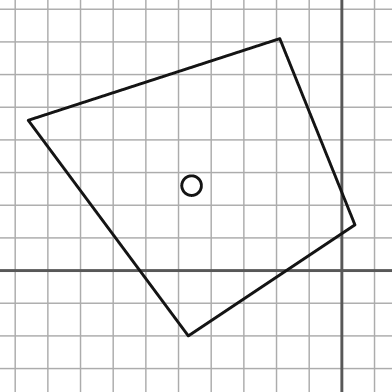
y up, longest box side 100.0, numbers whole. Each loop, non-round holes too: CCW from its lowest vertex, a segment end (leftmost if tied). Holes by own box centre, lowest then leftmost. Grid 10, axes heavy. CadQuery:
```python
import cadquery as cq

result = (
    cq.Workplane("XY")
    .moveTo(-47.0, -20.0)
    .lineTo(4.0, 14.0)
    .lineTo(-19.0, 71.0)
    .lineTo(-96.0, 46.0)
    .close()
    .moveTo(-46.0, 26.0)
    .circle(3.0)
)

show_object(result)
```